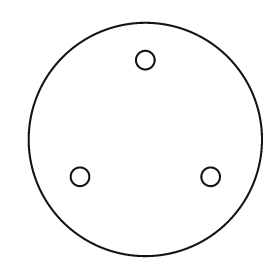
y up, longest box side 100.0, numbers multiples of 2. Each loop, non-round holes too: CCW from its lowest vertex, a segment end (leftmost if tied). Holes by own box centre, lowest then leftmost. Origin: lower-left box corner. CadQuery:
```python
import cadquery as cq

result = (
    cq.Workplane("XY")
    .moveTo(50.0, 50.0)
    .circle(50.0)
    .moveTo(22.0, 34.0)
    .circle(4.0)
    .moveTo(78.0, 34.0)
    .circle(4.0)
    .moveTo(50.0, 84.0)
    .circle(4.0)
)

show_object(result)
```